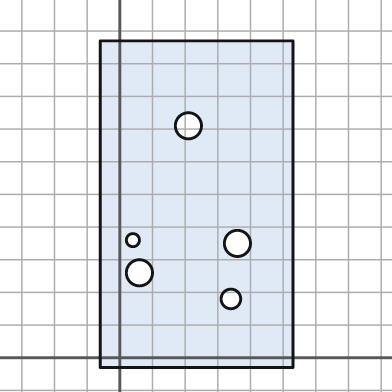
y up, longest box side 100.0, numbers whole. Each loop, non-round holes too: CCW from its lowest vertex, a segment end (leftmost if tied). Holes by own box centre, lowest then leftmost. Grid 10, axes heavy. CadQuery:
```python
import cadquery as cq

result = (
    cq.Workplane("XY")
    .moveTo(-6.0, -3.0)
    .lineTo(53.0, -3.0)
    .lineTo(53.0, 97.0)
    .lineTo(-6.0, 97.0)
    .close()
    .moveTo(34.0, 18.0)
    .circle(3.0)
    .moveTo(6.0, 26.0)
    .circle(4.0)
    .moveTo(36.0, 35.0)
    .circle(4.0)
    .moveTo(4.0, 36.0)
    .circle(2.0)
    .moveTo(21.0, 71.0)
    .circle(4.0)
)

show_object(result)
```